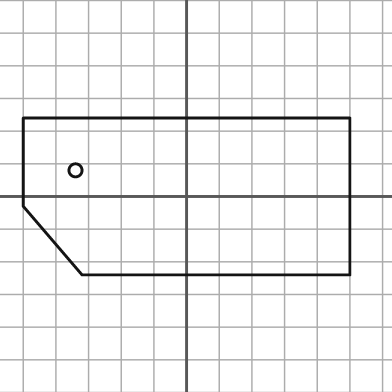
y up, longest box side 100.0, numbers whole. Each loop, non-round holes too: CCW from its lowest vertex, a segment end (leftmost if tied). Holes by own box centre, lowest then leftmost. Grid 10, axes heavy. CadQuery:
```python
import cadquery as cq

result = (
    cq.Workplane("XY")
    .moveTo(-32.0, -24.0)
    .lineTo(50.0, -24.0)
    .lineTo(50.0, 24.0)
    .lineTo(-50.0, 24.0)
    .lineTo(-50.0, -3.0)
    .close()
    .moveTo(-34.0, 8.0)
    .circle(2.0)
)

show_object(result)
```